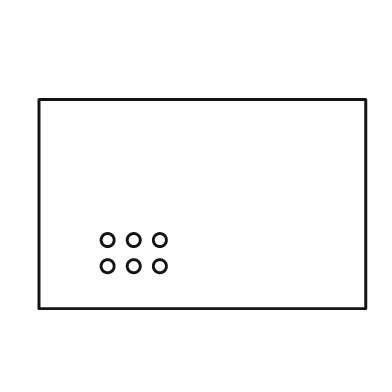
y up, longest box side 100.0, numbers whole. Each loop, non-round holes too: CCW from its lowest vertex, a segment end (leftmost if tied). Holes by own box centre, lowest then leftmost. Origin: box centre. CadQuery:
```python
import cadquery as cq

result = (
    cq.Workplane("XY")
    .moveTo(-50.0, -32.0)
    .lineTo(50.0, -32.0)
    .lineTo(50.0, 32.0)
    .lineTo(-50.0, 32.0)
    .close()
    .moveTo(-29.0, -19.0)
    .circle(2.0)
    .moveTo(-21.0, -19.0)
    .circle(2.0)
    .moveTo(-13.0, -19.0)
    .circle(2.0)
    .moveTo(-29.0, -11.0)
    .circle(2.0)
    .moveTo(-21.0, -11.0)
    .circle(2.0)
    .moveTo(-13.0, -11.0)
    .circle(2.0)
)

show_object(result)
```